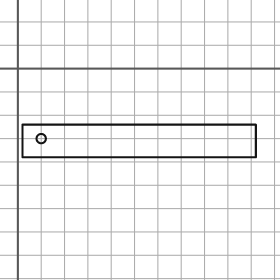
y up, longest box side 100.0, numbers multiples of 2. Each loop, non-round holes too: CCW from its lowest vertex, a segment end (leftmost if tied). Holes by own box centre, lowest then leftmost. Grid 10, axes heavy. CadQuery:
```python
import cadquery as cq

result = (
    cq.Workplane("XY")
    .moveTo(2.0, -38.0)
    .lineTo(102.0, -38.0)
    .lineTo(102.0, -24.0)
    .lineTo(2.0, -24.0)
    .close()
    .moveTo(10.0, -30.0)
    .circle(2.0)
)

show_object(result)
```